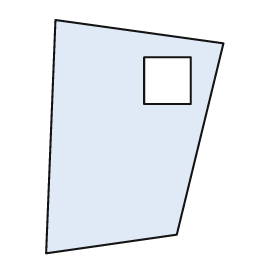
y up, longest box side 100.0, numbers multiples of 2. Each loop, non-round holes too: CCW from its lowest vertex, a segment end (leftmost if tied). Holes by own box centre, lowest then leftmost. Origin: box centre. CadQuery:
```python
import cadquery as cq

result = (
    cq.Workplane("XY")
    .moveTo(-38.0, -50.0)
    .lineTo(18.0, -42.0)
    .lineTo(38.0, 40.0)
    .lineTo(-34.0, 50.0)
    .close()
    .moveTo(4.0, 14.0)
    .lineTo(24.0, 14.0)
    .lineTo(24.0, 34.0)
    .lineTo(4.0, 34.0)
    .close()
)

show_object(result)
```